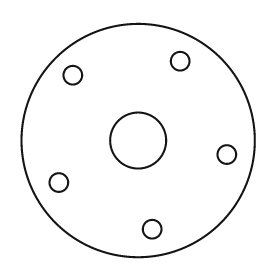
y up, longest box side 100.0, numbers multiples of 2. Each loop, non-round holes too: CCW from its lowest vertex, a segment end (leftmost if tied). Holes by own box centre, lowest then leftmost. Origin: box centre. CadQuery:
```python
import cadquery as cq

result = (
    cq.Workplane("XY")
    .moveTo(0.0, 0.0)
    .circle(50.0)
    .moveTo(6.0, -38.0)
    .circle(4.0)
    .moveTo(-34.0, -18.0)
    .circle(4.0)
    .moveTo(38.0, -6.0)
    .circle(4.0)
    .moveTo(0.0, 0.0)
    .circle(12.0)
    .moveTo(-28.0, 28.0)
    .circle(4.0)
    .moveTo(18.0, 34.0)
    .circle(4.0)
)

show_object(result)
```